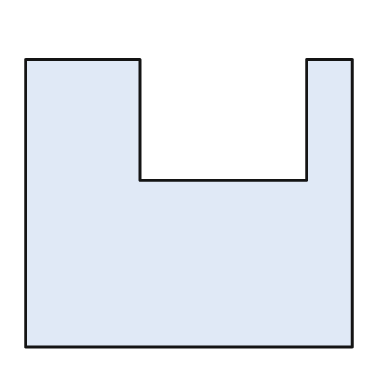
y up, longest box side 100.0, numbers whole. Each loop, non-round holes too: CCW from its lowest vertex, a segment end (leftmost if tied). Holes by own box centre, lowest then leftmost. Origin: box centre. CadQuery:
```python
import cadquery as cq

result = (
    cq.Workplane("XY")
    .moveTo(-50.0, -44.0)
    .lineTo(50.0, -44.0)
    .lineTo(50.0, 44.0)
    .lineTo(36.0, 44.0)
    .lineTo(36.0, 7.0)
    .lineTo(-15.0, 7.0)
    .lineTo(-15.0, 44.0)
    .lineTo(-50.0, 44.0)
    .close()
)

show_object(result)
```